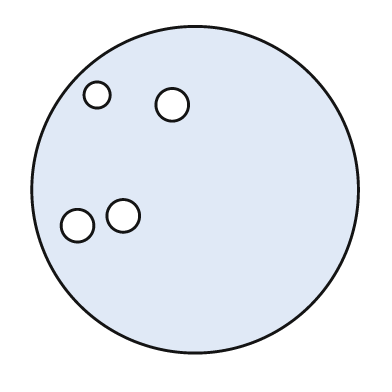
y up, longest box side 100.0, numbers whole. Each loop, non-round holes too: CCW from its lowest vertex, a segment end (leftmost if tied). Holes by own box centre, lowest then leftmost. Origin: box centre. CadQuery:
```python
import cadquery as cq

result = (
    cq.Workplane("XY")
    .moveTo(0.0, 0.0)
    .circle(50.0)
    .moveTo(-36.0, -11.0)
    .circle(5.0)
    .moveTo(-22.0, -8.0)
    .circle(5.0)
    .moveTo(-7.0, 26.0)
    .circle(5.0)
    .moveTo(-30.0, 29.0)
    .circle(4.0)
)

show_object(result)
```